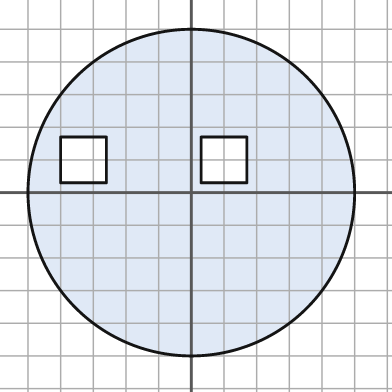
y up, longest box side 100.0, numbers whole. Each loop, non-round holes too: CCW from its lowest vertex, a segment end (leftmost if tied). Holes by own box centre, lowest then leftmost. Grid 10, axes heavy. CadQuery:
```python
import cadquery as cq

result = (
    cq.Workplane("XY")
    .moveTo(0.0, 0.0)
    .circle(50.0)
    .moveTo(-40.0, 3.0)
    .lineTo(-26.0, 3.0)
    .lineTo(-26.0, 17.0)
    .lineTo(-40.0, 17.0)
    .close()
    .moveTo(3.0, 3.0)
    .lineTo(17.0, 3.0)
    .lineTo(17.0, 17.0)
    .lineTo(3.0, 17.0)
    .close()
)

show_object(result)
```